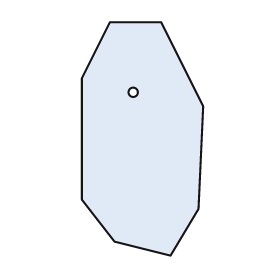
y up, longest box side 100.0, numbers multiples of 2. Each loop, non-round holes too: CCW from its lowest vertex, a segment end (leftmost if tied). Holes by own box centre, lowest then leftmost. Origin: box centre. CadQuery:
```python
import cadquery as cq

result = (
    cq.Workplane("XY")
    .moveTo(12.0, -50.0)
    .lineTo(24.0, -30.0)
    .lineTo(26.0, 14.0)
    .lineTo(8.0, 50.0)
    .lineTo(-14.0, 50.0)
    .lineTo(-26.0, 26.0)
    .lineTo(-26.0, -26.0)
    .lineTo(-12.0, -44.0)
    .close()
    .moveTo(-4.0, 20.0)
    .circle(2.0)
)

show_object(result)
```